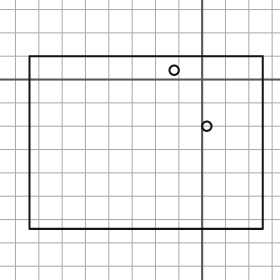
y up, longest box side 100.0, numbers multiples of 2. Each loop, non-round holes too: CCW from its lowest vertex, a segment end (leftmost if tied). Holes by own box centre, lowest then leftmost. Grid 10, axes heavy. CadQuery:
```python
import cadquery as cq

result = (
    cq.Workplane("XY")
    .moveTo(-74.0, -64.0)
    .lineTo(26.0, -64.0)
    .lineTo(26.0, 10.0)
    .lineTo(-74.0, 10.0)
    .close()
    .moveTo(2.0, -20.0)
    .circle(2.0)
    .moveTo(-12.0, 4.0)
    .circle(2.0)
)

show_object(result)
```